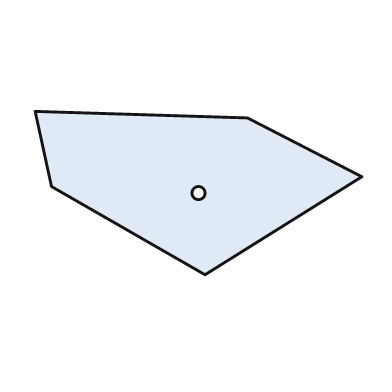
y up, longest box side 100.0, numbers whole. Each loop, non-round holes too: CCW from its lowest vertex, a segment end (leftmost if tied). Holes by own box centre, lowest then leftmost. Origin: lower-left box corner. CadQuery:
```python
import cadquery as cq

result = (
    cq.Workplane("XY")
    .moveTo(52.0, 0.0)
    .lineTo(100.0, 30.0)
    .lineTo(65.0, 48.0)
    .lineTo(0.0, 50.0)
    .lineTo(5.0, 27.0)
    .close()
    .moveTo(50.0, 25.0)
    .circle(2.0)
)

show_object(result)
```